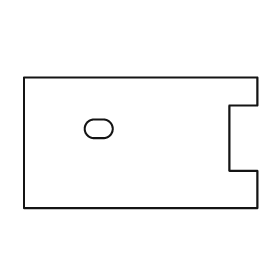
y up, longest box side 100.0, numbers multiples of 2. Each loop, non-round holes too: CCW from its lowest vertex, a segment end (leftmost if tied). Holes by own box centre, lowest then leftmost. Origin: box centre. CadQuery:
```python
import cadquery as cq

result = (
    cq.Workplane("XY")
    .moveTo(-50.0, -28.0)
    .lineTo(50.0, -28.0)
    .lineTo(50.0, -12.0)
    .lineTo(38.0, -12.0)
    .lineTo(38.0, 16.0)
    .lineTo(50.0, 16.0)
    .lineTo(50.0, 28.0)
    .lineTo(-50.0, 28.0)
    .close()
    .moveTo(-20.0, 2.0)
    .lineTo(-16.0, 2.0)
    .threePointArc((-12.0, 6.0), (-16.0, 10.0))
    .lineTo(-20.0, 10.0)
    .threePointArc((-24.0, 6.0), (-20.0, 2.0))
    .close()
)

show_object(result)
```